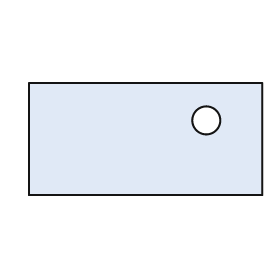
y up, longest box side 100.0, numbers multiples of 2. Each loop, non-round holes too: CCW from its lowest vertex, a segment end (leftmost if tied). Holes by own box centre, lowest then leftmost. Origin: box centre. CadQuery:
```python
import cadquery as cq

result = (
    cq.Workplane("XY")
    .moveTo(-50.0, -24.0)
    .lineTo(50.0, -24.0)
    .lineTo(50.0, 24.0)
    .lineTo(-50.0, 24.0)
    .close()
    .moveTo(26.0, 8.0)
    .circle(6.0)
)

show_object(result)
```